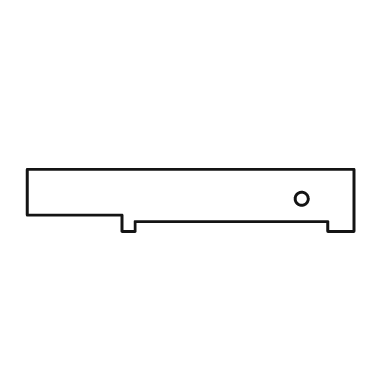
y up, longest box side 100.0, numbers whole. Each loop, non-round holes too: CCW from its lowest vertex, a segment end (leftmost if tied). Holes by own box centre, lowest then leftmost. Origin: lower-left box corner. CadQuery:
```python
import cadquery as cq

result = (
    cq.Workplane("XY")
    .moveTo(29.0, 0.0)
    .lineTo(33.0, 0.0)
    .lineTo(33.0, 3.0)
    .lineTo(92.0, 3.0)
    .lineTo(92.0, 0.0)
    .lineTo(100.0, 0.0)
    .lineTo(100.0, 19.0)
    .lineTo(0.0, 19.0)
    .lineTo(0.0, 5.0)
    .lineTo(29.0, 5.0)
    .close()
    .moveTo(84.0, 10.0)
    .circle(2.0)
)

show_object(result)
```